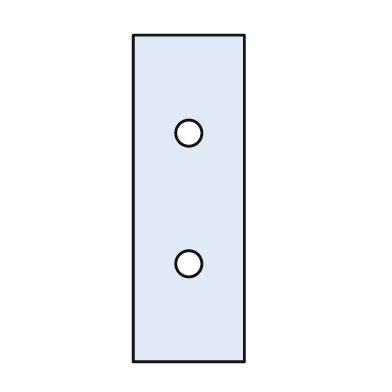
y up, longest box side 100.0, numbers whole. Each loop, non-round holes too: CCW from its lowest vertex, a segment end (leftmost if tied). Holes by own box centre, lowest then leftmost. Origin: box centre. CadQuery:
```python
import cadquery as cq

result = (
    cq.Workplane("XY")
    .moveTo(-17.0, -50.0)
    .lineTo(17.0, -50.0)
    .lineTo(17.0, 50.0)
    .lineTo(-17.0, 50.0)
    .close()
    .moveTo(0.0, -20.0)
    .circle(4.0)
    .moveTo(0.0, 20.0)
    .circle(4.0)
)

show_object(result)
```